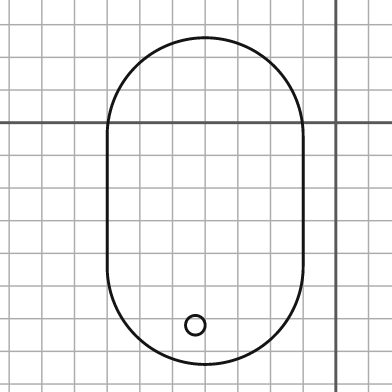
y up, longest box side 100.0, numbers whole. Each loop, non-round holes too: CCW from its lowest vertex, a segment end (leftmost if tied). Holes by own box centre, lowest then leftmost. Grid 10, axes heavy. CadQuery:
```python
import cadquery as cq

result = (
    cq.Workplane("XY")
    .moveTo(-70.0, -44.0)
    .threePointArc((-40.0, -74.0), (-10.0, -44.0))
    .lineTo(-10.0, -4.0)
    .threePointArc((-40.0, 26.0), (-70.0, -4.0))
    .close()
    .moveTo(-43.0, -62.0)
    .circle(3.0)
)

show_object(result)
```